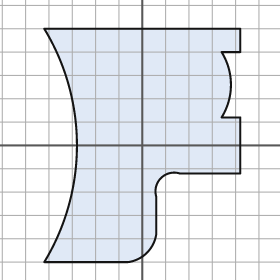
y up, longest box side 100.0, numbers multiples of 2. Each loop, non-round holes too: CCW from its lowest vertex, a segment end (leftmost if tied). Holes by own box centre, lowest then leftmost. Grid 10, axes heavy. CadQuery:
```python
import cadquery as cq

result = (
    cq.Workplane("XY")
    .moveTo(-42.0, -50.0)
    .lineTo(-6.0, -50.0)
    .threePointArc((2.0, -46.0), (6.0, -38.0))
    .lineTo(6.0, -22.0)
    .threePointArc((8.0, -14.0), (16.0, -12.0))
    .lineTo(42.0, -12.0)
    .lineTo(42.0, 12.0)
    .lineTo(34.0, 12.0)
    .threePointArc((38.0, 26.0), (34.0, 40.0))
    .lineTo(42.0, 40.0)
    .lineTo(42.0, 50.0)
    .lineTo(-42.0, 50.0)
    .threePointArc((-28.0, 0.0), (-42.0, -50.0))
    .close()
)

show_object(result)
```